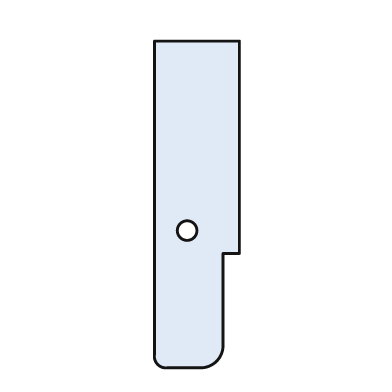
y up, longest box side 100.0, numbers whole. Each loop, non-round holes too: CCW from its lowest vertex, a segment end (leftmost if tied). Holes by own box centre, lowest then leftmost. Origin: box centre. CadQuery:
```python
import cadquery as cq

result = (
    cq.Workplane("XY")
    .moveTo(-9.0, -50.0)
    .lineTo(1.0, -50.0)
    .threePointArc((6.0, -48.0), (8.0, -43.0))
    .lineTo(8.0, -15.0)
    .lineTo(13.0, -15.0)
    .lineTo(13.0, 50.0)
    .lineTo(-13.0, 50.0)
    .lineTo(-13.0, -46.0)
    .threePointArc((-12.0, -49.0), (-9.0, -50.0))
    .close()
    .moveTo(-3.0, -8.0)
    .circle(3.0)
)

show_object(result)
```